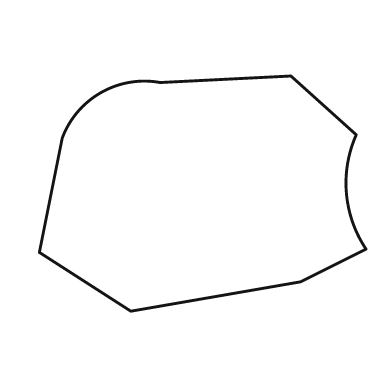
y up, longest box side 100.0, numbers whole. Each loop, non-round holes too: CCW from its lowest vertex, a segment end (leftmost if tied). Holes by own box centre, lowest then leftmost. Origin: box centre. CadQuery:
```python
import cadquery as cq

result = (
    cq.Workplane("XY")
    .moveTo(-22.0, -36.0)
    .lineTo(30.0, -27.0)
    .lineTo(50.0, -17.0)
    .threePointArc((44.0, 0.0), (47.0, 18.0))
    .lineTo(27.0, 36.0)
    .lineTo(-13.0, 34.0)
    .threePointArc((-31.0, 31.0), (-43.0, 17.0))
    .lineTo(-50.0, -18.0)
    .close()
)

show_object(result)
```